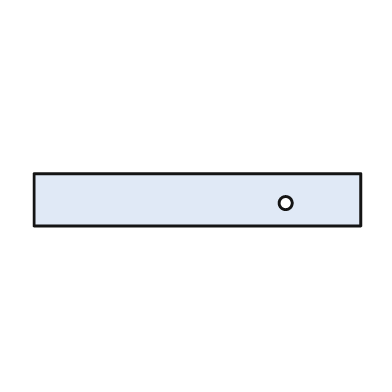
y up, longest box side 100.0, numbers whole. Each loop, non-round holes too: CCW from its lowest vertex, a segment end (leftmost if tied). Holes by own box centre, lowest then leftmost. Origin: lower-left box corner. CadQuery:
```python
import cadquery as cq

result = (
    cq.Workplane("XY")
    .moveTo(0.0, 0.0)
    .lineTo(100.0, 0.0)
    .lineTo(100.0, 16.0)
    .lineTo(0.0, 16.0)
    .close()
    .moveTo(77.0, 7.0)
    .circle(2.0)
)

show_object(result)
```